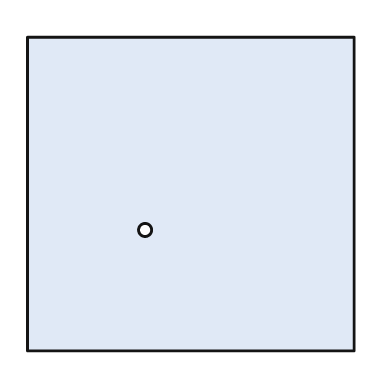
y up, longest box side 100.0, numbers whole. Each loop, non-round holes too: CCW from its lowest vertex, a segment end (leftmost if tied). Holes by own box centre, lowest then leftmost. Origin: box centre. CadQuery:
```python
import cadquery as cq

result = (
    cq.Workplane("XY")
    .moveTo(-50.0, -48.0)
    .lineTo(50.0, -48.0)
    .lineTo(50.0, 48.0)
    .lineTo(-50.0, 48.0)
    .close()
    .moveTo(-14.0, -11.0)
    .circle(2.0)
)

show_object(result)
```